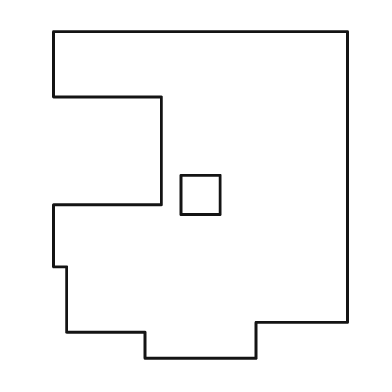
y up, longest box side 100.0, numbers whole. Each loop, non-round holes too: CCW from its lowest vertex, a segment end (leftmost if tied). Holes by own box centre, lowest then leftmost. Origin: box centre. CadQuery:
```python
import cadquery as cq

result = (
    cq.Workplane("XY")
    .moveTo(-17.0, -50.0)
    .lineTo(17.0, -50.0)
    .lineTo(17.0, -39.0)
    .lineTo(45.0, -39.0)
    .lineTo(45.0, 50.0)
    .lineTo(-45.0, 50.0)
    .lineTo(-45.0, 30.0)
    .lineTo(-12.0, 30.0)
    .lineTo(-12.0, -3.0)
    .lineTo(-45.0, -3.0)
    .lineTo(-45.0, -22.0)
    .lineTo(-41.0, -22.0)
    .lineTo(-41.0, -42.0)
    .lineTo(-17.0, -42.0)
    .close()
    .moveTo(-6.0, -6.0)
    .lineTo(6.0, -6.0)
    .lineTo(6.0, 6.0)
    .lineTo(-6.0, 6.0)
    .close()
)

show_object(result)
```